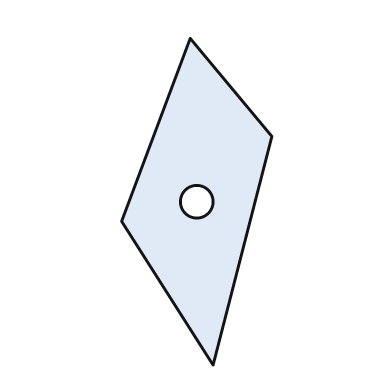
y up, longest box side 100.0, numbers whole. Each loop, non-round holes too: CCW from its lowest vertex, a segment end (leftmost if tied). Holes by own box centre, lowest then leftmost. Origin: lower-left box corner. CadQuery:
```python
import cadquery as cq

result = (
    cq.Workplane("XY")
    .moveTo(28.0, 0.0)
    .lineTo(46.0, 70.0)
    .lineTo(21.0, 100.0)
    .lineTo(0.0, 44.0)
    .close()
    .moveTo(23.0, 50.0)
    .circle(5.0)
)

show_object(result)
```